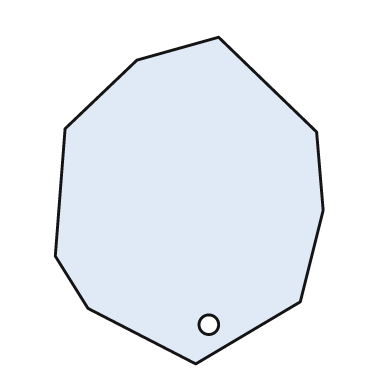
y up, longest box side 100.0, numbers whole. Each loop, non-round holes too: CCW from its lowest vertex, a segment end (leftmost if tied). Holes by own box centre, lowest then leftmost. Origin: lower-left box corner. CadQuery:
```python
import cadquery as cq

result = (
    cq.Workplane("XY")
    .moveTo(43.0, 0.0)
    .lineTo(75.0, 19.0)
    .lineTo(82.0, 47.0)
    .lineTo(80.0, 71.0)
    .lineTo(50.0, 100.0)
    .lineTo(25.0, 93.0)
    .lineTo(3.0, 72.0)
    .lineTo(0.0, 33.0)
    .lineTo(10.0, 17.0)
    .close()
    .moveTo(47.0, 12.0)
    .circle(3.0)
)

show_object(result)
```